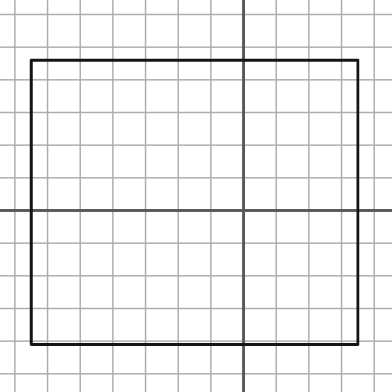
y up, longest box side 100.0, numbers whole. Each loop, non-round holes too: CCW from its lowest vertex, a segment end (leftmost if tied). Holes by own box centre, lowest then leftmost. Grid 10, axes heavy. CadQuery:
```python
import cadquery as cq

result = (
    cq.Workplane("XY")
    .moveTo(-65.0, -41.0)
    .lineTo(35.0, -41.0)
    .lineTo(35.0, 46.0)
    .lineTo(-65.0, 46.0)
    .close()
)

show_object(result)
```